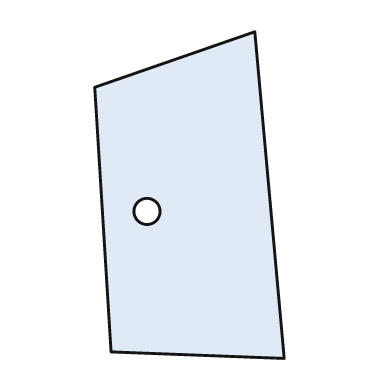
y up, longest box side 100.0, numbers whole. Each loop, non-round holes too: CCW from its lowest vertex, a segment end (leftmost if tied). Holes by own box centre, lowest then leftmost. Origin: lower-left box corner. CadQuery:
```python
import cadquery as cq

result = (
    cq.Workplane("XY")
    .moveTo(58.0, 0.0)
    .lineTo(49.0, 100.0)
    .lineTo(0.0, 83.0)
    .lineTo(5.0, 2.0)
    .close()
    .moveTo(16.0, 45.0)
    .circle(4.0)
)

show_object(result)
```